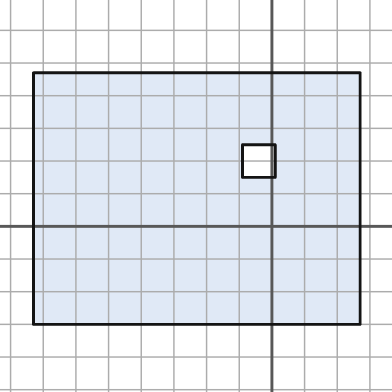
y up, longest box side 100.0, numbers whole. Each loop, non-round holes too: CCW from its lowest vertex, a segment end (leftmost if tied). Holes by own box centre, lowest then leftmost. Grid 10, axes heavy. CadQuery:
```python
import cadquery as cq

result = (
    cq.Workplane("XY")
    .moveTo(-73.0, -30.0)
    .lineTo(27.0, -30.0)
    .lineTo(27.0, 47.0)
    .lineTo(-73.0, 47.0)
    .close()
    .moveTo(-9.0, 15.0)
    .lineTo(1.0, 15.0)
    .lineTo(1.0, 25.0)
    .lineTo(-9.0, 25.0)
    .close()
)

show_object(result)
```